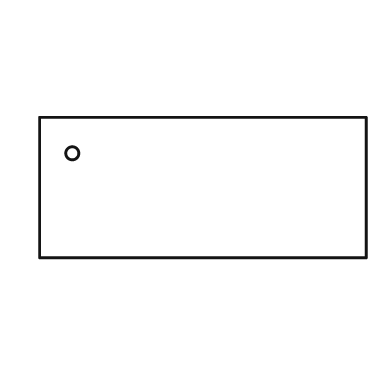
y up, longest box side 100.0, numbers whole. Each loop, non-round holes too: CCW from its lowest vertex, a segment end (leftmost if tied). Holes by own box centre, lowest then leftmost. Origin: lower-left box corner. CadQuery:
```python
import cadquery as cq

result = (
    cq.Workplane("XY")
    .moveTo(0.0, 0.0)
    .lineTo(100.0, 0.0)
    .lineTo(100.0, 43.0)
    .lineTo(0.0, 43.0)
    .close()
    .moveTo(10.0, 32.0)
    .circle(2.0)
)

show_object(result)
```